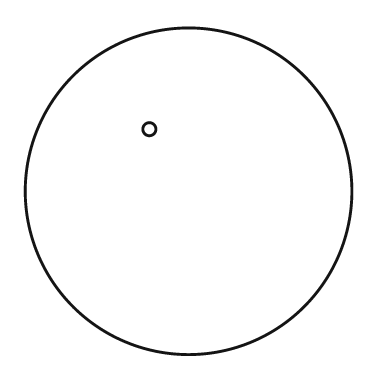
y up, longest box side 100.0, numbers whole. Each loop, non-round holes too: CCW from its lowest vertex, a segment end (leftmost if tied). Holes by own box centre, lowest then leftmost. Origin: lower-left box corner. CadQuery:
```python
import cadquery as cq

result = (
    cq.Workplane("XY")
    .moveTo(50.0, 50.0)
    .circle(50.0)
    .moveTo(38.0, 69.0)
    .circle(2.0)
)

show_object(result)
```